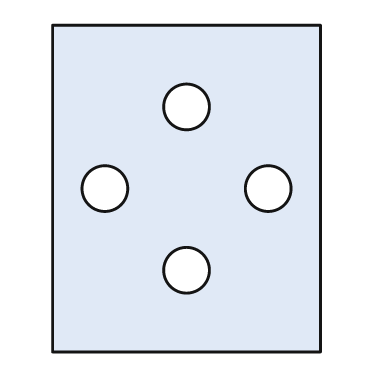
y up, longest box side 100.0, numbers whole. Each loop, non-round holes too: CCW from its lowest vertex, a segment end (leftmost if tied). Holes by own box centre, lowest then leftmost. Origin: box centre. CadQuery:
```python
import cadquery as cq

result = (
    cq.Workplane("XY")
    .moveTo(-41.0, -50.0)
    .lineTo(41.0, -50.0)
    .lineTo(41.0, 50.0)
    .lineTo(-41.0, 50.0)
    .close()
    .moveTo(0.0, -25.0)
    .circle(7.0)
    .moveTo(-25.0, 0.0)
    .circle(7.0)
    .moveTo(25.0, 0.0)
    .circle(7.0)
    .moveTo(0.0, 25.0)
    .circle(7.0)
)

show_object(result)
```